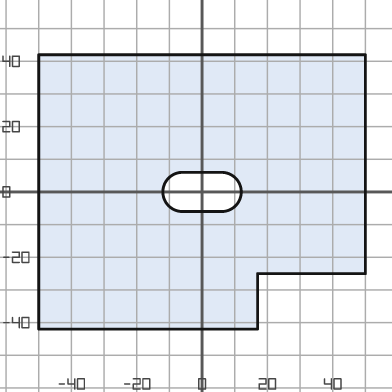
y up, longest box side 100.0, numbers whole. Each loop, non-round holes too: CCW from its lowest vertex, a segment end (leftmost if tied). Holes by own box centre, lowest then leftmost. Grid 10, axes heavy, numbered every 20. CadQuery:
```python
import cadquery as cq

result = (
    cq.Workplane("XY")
    .moveTo(-50.0, -42.0)
    .lineTo(17.0, -42.0)
    .lineTo(17.0, -25.0)
    .lineTo(50.0, -25.0)
    .lineTo(50.0, 42.0)
    .lineTo(-50.0, 42.0)
    .close()
    .moveTo(-6.0, -6.0)
    .lineTo(6.0, -6.0)
    .threePointArc((12.0, 0.0), (6.0, 6.0))
    .lineTo(-6.0, 6.0)
    .threePointArc((-12.0, 0.0), (-6.0, -6.0))
    .close()
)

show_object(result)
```